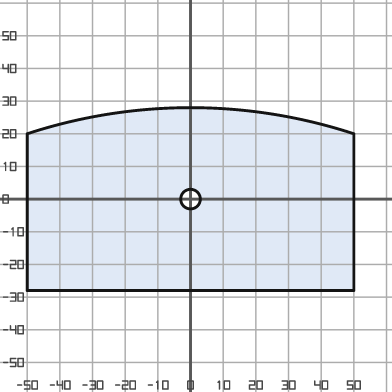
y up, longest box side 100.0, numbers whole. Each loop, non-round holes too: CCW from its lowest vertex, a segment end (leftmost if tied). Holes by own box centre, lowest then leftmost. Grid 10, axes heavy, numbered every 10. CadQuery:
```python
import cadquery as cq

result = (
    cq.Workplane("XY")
    .moveTo(-50.0, -28.0)
    .lineTo(50.0, -28.0)
    .lineTo(50.0, 20.0)
    .threePointArc((0.0, 28.0), (-50.0, 20.0))
    .close()
    .moveTo(0.0, 0.0)
    .circle(3.0)
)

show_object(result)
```